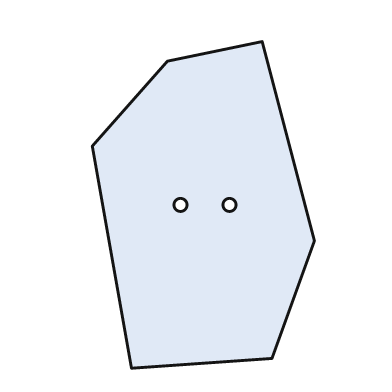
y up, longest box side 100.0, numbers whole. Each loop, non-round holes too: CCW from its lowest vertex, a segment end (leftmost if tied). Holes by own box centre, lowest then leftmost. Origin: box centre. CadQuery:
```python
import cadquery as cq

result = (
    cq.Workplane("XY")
    .moveTo(-22.0, -50.0)
    .lineTo(21.0, -47.0)
    .lineTo(34.0, -11.0)
    .lineTo(18.0, 50.0)
    .lineTo(-11.0, 44.0)
    .lineTo(-34.0, 18.0)
    .close()
    .moveTo(-7.0, 0.0)
    .circle(2.0)
    .moveTo(8.0, 0.0)
    .circle(2.0)
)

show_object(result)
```